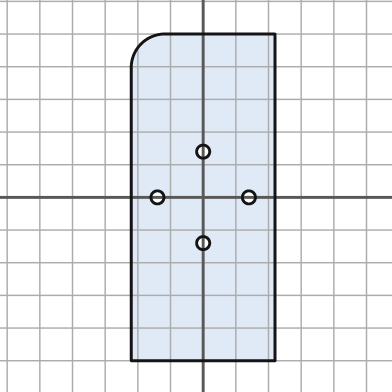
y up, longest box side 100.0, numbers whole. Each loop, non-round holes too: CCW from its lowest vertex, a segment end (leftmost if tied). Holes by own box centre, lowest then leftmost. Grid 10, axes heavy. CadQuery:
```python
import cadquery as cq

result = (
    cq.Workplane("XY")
    .moveTo(-22.0, -50.0)
    .lineTo(22.0, -50.0)
    .lineTo(22.0, 50.0)
    .lineTo(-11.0, 50.0)
    .threePointArc((-19.0, 47.0), (-22.0, 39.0))
    .close()
    .moveTo(0.0, -14.0)
    .circle(2.0)
    .moveTo(-14.0, 0.0)
    .circle(2.0)
    .moveTo(14.0, 0.0)
    .circle(2.0)
    .moveTo(0.0, 14.0)
    .circle(2.0)
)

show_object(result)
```